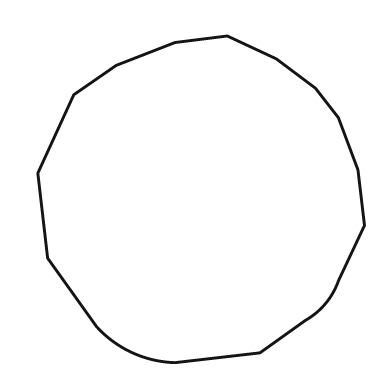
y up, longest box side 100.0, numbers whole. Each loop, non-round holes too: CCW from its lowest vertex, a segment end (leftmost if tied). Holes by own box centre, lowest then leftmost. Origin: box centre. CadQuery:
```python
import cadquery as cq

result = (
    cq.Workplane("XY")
    .moveTo(-8.0, -50.0)
    .lineTo(18.0, -47.0)
    .lineTo(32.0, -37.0)
    .threePointArc((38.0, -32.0), (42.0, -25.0))
    .lineTo(50.0, -8.0)
    .lineTo(48.0, 9.0)
    .lineTo(42.0, 25.0)
    .lineTo(35.0, 34.0)
    .lineTo(23.0, 43.0)
    .lineTo(8.0, 50.0)
    .lineTo(-8.0, 48.0)
    .lineTo(-26.0, 41.0)
    .lineTo(-39.0, 32.0)
    .lineTo(-50.0, 8.0)
    .lineTo(-47.0, -18.0)
    .lineTo(-32.0, -39.0)
    .threePointArc((-21.0, -47.0), (-8.0, -50.0))
    .close()
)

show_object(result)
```